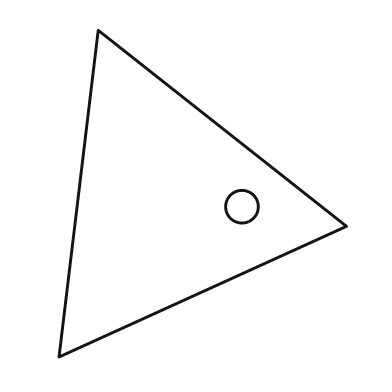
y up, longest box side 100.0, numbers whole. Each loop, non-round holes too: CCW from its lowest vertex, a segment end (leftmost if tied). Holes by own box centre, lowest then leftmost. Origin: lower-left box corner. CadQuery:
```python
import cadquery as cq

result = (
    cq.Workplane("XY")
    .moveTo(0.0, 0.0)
    .lineTo(88.0, 40.0)
    .lineTo(12.0, 100.0)
    .close()
    .moveTo(56.0, 46.0)
    .circle(5.0)
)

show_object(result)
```